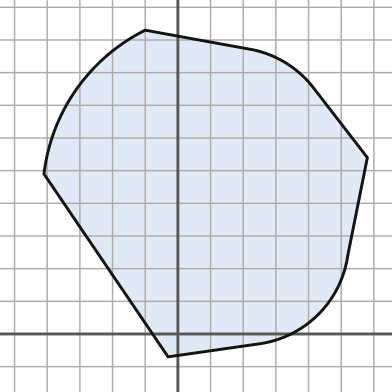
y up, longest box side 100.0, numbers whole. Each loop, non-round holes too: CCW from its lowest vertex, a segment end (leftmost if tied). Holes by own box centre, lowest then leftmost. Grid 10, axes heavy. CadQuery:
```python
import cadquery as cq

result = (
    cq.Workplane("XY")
    .moveTo(-3.0, -7.0)
    .lineTo(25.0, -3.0)
    .threePointArc((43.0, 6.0), (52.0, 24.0))
    .lineTo(58.0, 54.0)
    .lineTo(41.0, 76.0)
    .threePointArc((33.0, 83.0), (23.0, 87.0))
    .lineTo(-10.0, 93.0)
    .threePointArc((-31.0, 75.0), (-41.0, 49.0))
    .close()
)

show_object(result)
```